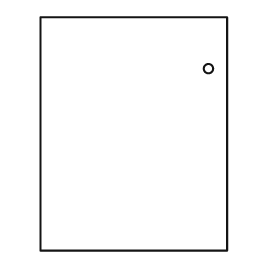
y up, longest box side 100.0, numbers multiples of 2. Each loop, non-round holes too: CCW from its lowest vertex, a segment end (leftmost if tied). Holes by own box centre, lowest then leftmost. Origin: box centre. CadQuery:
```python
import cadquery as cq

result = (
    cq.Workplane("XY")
    .moveTo(-40.0, -50.0)
    .lineTo(40.0, -50.0)
    .lineTo(40.0, 50.0)
    .lineTo(-40.0, 50.0)
    .close()
    .moveTo(32.0, 28.0)
    .circle(2.0)
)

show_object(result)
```